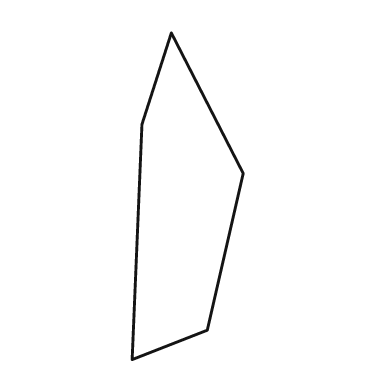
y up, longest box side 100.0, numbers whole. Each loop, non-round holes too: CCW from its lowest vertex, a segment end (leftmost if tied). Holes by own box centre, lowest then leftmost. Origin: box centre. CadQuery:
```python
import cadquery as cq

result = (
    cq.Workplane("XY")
    .moveTo(-17.0, -50.0)
    .lineTo(6.0, -41.0)
    .lineTo(17.0, 7.0)
    .lineTo(-5.0, 50.0)
    .lineTo(-14.0, 22.0)
    .close()
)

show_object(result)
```